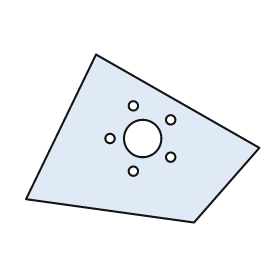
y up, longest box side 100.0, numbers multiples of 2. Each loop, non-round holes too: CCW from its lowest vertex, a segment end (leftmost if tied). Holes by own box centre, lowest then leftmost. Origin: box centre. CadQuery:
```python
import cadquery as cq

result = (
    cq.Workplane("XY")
    .moveTo(22.0, -36.0)
    .lineTo(50.0, -4.0)
    .lineTo(-20.0, 36.0)
    .lineTo(-50.0, -26.0)
    .close()
    .moveTo(-4.0, -14.0)
    .circle(2.0)
    .moveTo(12.0, -8.0)
    .circle(2.0)
    .moveTo(-14.0, 0.0)
    .circle(2.0)
    .moveTo(0.0, 0.0)
    .circle(8.0)
    .moveTo(12.0, 8.0)
    .circle(2.0)
    .moveTo(-4.0, 14.0)
    .circle(2.0)
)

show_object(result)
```